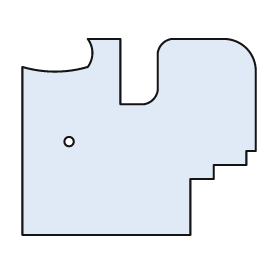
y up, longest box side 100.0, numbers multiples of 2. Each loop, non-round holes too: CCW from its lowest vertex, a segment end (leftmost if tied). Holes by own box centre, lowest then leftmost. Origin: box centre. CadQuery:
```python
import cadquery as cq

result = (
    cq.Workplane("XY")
    .moveTo(-50.0, -42.0)
    .lineTo(22.0, -42.0)
    .lineTo(22.0, -18.0)
    .lineTo(32.0, -18.0)
    .lineTo(32.0, -12.0)
    .lineTo(46.0, -12.0)
    .lineTo(46.0, -6.0)
    .lineTo(50.0, -6.0)
    .lineTo(50.0, 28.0)
    .threePointArc((46.0, 38.0), (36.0, 42.0))
    .lineTo(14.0, 42.0)
    .threePointArc((10.0, 40.0), (8.0, 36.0))
    .lineTo(8.0, 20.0)
    .threePointArc((6.0, 16.0), (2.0, 14.0))
    .lineTo(-8.0, 14.0)
    .lineTo(-8.0, 42.0)
    .lineTo(-22.0, 42.0)
    .threePointArc((-20.0, 36.0), (-22.0, 30.0))
    .threePointArc((-36.0, 28.0), (-50.0, 30.0))
    .close()
    .moveTo(-30.0, -2.0)
    .circle(2.0)
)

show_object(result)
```